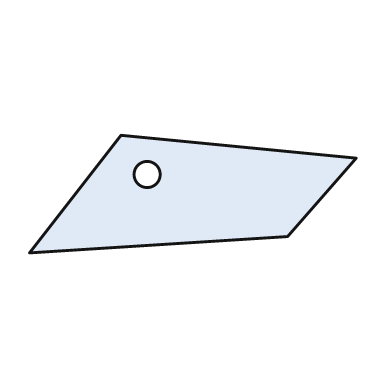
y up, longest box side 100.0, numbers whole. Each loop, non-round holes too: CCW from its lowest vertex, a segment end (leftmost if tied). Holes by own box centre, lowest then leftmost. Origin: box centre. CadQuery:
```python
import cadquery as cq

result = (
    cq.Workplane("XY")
    .moveTo(-50.0, -18.0)
    .lineTo(29.0, -13.0)
    .lineTo(50.0, 11.0)
    .lineTo(-22.0, 18.0)
    .close()
    .moveTo(-14.0, 6.0)
    .circle(4.0)
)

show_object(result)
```